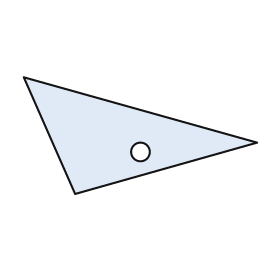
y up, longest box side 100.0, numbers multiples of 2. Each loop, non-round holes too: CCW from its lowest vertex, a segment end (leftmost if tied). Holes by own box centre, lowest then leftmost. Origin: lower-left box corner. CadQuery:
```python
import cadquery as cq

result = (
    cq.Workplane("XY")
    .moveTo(22.0, 0.0)
    .lineTo(100.0, 22.0)
    .lineTo(0.0, 50.0)
    .close()
    .moveTo(50.0, 18.0)
    .circle(4.0)
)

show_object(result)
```